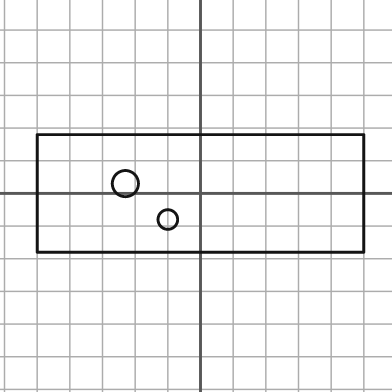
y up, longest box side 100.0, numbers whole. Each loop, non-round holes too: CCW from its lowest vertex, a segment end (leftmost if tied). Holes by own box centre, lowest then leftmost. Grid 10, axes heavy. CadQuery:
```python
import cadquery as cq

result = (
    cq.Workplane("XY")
    .moveTo(-50.0, -18.0)
    .lineTo(50.0, -18.0)
    .lineTo(50.0, 18.0)
    .lineTo(-50.0, 18.0)
    .close()
    .moveTo(-10.0, -8.0)
    .circle(3.0)
    .moveTo(-23.0, 3.0)
    .circle(4.0)
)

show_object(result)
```